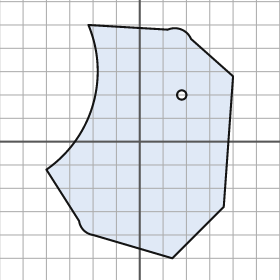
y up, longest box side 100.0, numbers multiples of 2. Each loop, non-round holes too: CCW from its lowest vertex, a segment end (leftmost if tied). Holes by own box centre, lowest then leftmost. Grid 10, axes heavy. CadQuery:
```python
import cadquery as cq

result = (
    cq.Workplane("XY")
    .moveTo(14.0, -50.0)
    .lineTo(36.0, -28.0)
    .lineTo(40.0, 28.0)
    .lineTo(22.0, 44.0)
    .threePointArc((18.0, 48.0), (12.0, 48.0))
    .lineTo(-22.0, 50.0)
    .threePointArc((-20.0, 16.0), (-40.0, -12.0))
    .lineTo(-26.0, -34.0)
    .threePointArc((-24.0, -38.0), (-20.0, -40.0))
    .close()
    .moveTo(18.0, 20.0)
    .circle(2.0)
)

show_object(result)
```